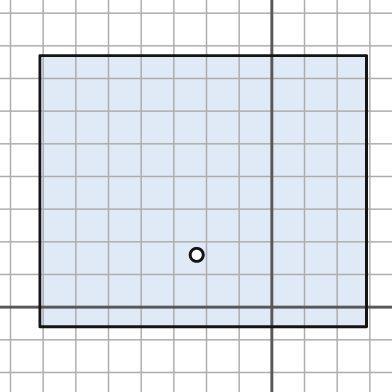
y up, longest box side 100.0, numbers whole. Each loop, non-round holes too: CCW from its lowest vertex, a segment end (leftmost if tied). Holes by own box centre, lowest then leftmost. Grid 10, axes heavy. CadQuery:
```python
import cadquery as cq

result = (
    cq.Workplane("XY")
    .moveTo(-71.0, -6.0)
    .lineTo(29.0, -6.0)
    .lineTo(29.0, 77.0)
    .lineTo(-71.0, 77.0)
    .close()
    .moveTo(-23.0, 16.0)
    .circle(2.0)
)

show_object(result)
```